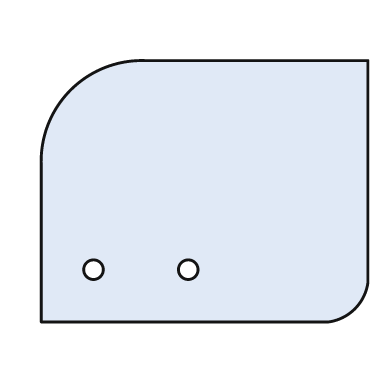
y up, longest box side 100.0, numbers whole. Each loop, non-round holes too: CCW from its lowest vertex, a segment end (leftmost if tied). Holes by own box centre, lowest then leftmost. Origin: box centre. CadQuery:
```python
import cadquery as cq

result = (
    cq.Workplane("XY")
    .moveTo(-50.0, -40.0)
    .lineTo(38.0, -40.0)
    .threePointArc((46.0, -36.0), (50.0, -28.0))
    .lineTo(50.0, 40.0)
    .lineTo(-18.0, 40.0)
    .threePointArc((-41.0, 31.0), (-50.0, 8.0))
    .close()
    .moveTo(-34.0, -24.0)
    .circle(3.0)
    .moveTo(-5.0, -24.0)
    .circle(3.0)
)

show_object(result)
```